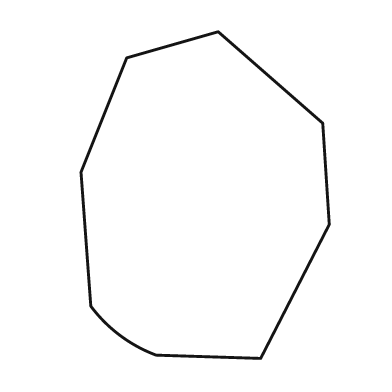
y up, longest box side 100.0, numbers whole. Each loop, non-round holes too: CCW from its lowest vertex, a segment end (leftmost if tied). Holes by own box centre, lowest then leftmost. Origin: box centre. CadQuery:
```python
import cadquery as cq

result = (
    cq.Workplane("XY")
    .moveTo(17.0, -50.0)
    .lineTo(38.0, -9.0)
    .lineTo(36.0, 22.0)
    .lineTo(4.0, 50.0)
    .lineTo(-24.0, 42.0)
    .lineTo(-38.0, 7.0)
    .lineTo(-35.0, -34.0)
    .threePointArc((-26.0, -43.0), (-15.0, -49.0))
    .close()
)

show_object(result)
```